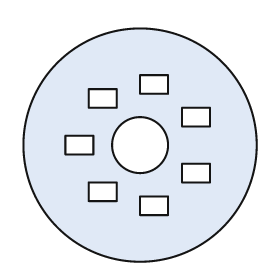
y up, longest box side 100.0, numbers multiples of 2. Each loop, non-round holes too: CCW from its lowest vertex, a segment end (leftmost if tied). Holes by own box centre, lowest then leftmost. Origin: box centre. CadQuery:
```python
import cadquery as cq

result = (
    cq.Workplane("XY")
    .moveTo(0.0, 0.0)
    .circle(50.0)
    .moveTo(0.0, -30.0)
    .lineTo(12.0, -30.0)
    .lineTo(12.0, -22.0)
    .lineTo(0.0, -22.0)
    .close()
    .moveTo(-22.0, -24.0)
    .lineTo(-10.0, -24.0)
    .lineTo(-10.0, -16.0)
    .lineTo(-22.0, -16.0)
    .close()
    .moveTo(18.0, -16.0)
    .lineTo(30.0, -16.0)
    .lineTo(30.0, -8.0)
    .lineTo(18.0, -8.0)
    .close()
    .moveTo(-32.0, -4.0)
    .lineTo(-20.0, -4.0)
    .lineTo(-20.0, 4.0)
    .lineTo(-32.0, 4.0)
    .close()
    .moveTo(0.0, 0.0)
    .circle(12.0)
    .moveTo(18.0, 8.0)
    .lineTo(30.0, 8.0)
    .lineTo(30.0, 16.0)
    .lineTo(18.0, 16.0)
    .close()
    .moveTo(-22.0, 16.0)
    .lineTo(-10.0, 16.0)
    .lineTo(-10.0, 24.0)
    .lineTo(-22.0, 24.0)
    .close()
    .moveTo(0.0, 22.0)
    .lineTo(12.0, 22.0)
    .lineTo(12.0, 30.0)
    .lineTo(0.0, 30.0)
    .close()
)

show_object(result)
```